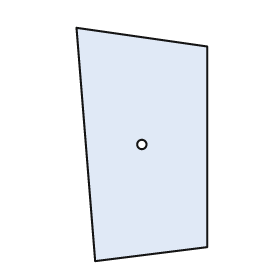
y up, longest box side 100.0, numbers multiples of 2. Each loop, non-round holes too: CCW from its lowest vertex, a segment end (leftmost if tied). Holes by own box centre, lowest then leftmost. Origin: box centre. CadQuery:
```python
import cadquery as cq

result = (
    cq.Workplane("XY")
    .moveTo(-20.0, -50.0)
    .lineTo(28.0, -44.0)
    .lineTo(28.0, 42.0)
    .lineTo(-28.0, 50.0)
    .close()
    .moveTo(0.0, 0.0)
    .circle(2.0)
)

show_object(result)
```